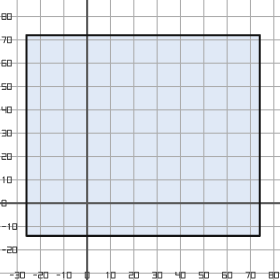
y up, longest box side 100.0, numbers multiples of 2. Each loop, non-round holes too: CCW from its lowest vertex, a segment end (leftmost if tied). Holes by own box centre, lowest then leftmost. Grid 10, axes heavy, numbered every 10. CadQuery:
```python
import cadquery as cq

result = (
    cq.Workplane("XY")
    .moveTo(-26.0, -14.0)
    .lineTo(74.0, -14.0)
    .lineTo(74.0, 72.0)
    .lineTo(-26.0, 72.0)
    .close()
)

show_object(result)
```